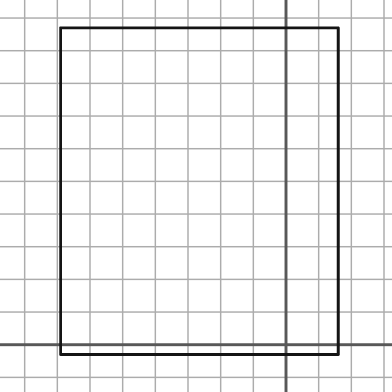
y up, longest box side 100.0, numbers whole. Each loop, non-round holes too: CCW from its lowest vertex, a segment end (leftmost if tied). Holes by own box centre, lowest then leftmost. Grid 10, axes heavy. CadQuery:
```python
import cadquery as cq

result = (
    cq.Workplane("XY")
    .moveTo(-69.0, -3.0)
    .lineTo(16.0, -3.0)
    .lineTo(16.0, 97.0)
    .lineTo(-69.0, 97.0)
    .close()
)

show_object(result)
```